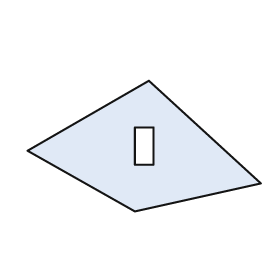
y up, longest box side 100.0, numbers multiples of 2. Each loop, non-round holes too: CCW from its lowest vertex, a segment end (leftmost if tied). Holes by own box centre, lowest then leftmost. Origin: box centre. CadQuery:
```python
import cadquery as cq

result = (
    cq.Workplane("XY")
    .moveTo(-4.0, -28.0)
    .lineTo(50.0, -16.0)
    .lineTo(2.0, 28.0)
    .lineTo(-50.0, -2.0)
    .close()
    .moveTo(-4.0, -8.0)
    .lineTo(4.0, -8.0)
    .lineTo(4.0, 8.0)
    .lineTo(-4.0, 8.0)
    .close()
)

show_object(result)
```